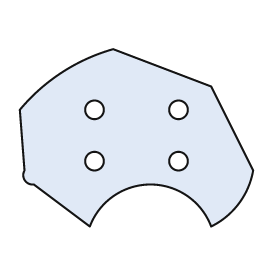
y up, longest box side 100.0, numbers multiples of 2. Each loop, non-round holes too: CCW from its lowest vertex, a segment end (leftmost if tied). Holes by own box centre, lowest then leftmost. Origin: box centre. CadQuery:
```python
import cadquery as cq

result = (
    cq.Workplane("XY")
    .moveTo(-20.0, -38.0)
    .threePointArc((6.0, -20.0), (32.0, -38.0))
    .threePointArc((44.0, -28.0), (50.0, -14.0))
    .lineTo(32.0, 22.0)
    .lineTo(-10.0, 38.0)
    .threePointArc((-32.0, 28.0), (-50.0, 12.0))
    .lineTo(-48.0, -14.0)
    .threePointArc((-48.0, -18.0), (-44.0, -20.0))
    .close()
    .moveTo(-18.0, -10.0)
    .circle(4.0)
    .moveTo(18.0, -10.0)
    .circle(4.0)
    .moveTo(-18.0, 12.0)
    .circle(4.0)
    .moveTo(18.0, 12.0)
    .circle(4.0)
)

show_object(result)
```